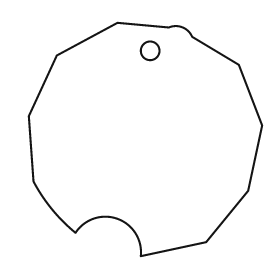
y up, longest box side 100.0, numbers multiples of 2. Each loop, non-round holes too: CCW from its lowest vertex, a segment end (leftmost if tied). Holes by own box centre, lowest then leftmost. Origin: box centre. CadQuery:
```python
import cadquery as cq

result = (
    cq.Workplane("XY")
    .moveTo(-2.0, -50.0)
    .lineTo(26.0, -44.0)
    .lineTo(44.0, -22.0)
    .lineTo(50.0, 6.0)
    .lineTo(40.0, 32.0)
    .lineTo(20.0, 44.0)
    .threePointArc((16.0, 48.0), (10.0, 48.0))
    .lineTo(-12.0, 50.0)
    .lineTo(-38.0, 36.0)
    .lineTo(-50.0, 10.0)
    .lineTo(-48.0, -18.0)
    .threePointArc((-40.0, -30.0), (-30.0, -40.0))
    .threePointArc((-12.0, -34.0), (-2.0, -50.0))
    .close()
    .moveTo(2.0, 38.0)
    .circle(4.0)
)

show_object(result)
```